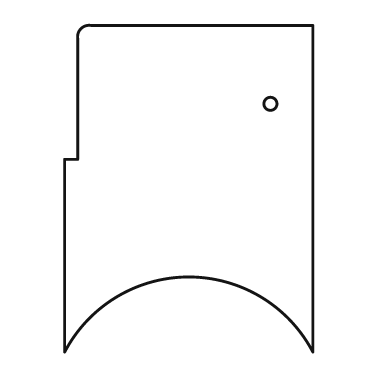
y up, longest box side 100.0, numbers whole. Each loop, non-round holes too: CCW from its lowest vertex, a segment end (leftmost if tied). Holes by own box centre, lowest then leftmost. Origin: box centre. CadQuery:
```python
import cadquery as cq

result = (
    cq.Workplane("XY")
    .moveTo(-38.0, -50.0)
    .threePointArc((0.0, -27.0), (38.0, -50.0))
    .lineTo(38.0, 50.0)
    .lineTo(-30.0, 50.0)
    .threePointArc((-33.0, 49.0), (-34.0, 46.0))
    .lineTo(-34.0, 9.0)
    .lineTo(-38.0, 9.0)
    .close()
    .moveTo(25.0, 26.0)
    .circle(2.0)
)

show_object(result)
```